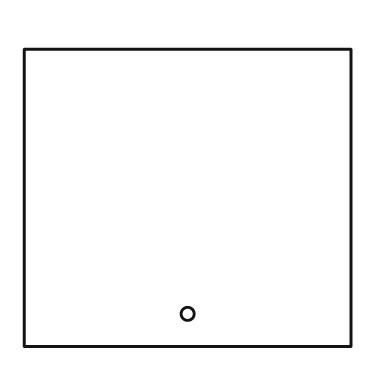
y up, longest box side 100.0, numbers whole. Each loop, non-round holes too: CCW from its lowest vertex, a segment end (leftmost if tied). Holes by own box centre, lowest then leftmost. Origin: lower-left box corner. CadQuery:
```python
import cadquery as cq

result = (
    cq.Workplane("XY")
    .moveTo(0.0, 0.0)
    .lineTo(100.0, 0.0)
    .lineTo(100.0, 91.0)
    .lineTo(0.0, 91.0)
    .close()
    .moveTo(50.0, 10.0)
    .circle(2.0)
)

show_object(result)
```